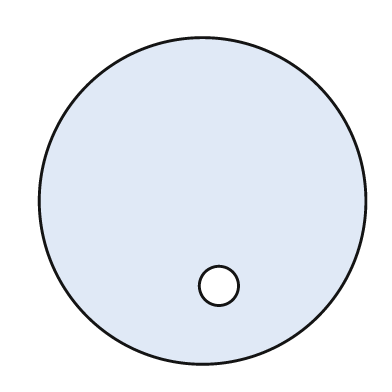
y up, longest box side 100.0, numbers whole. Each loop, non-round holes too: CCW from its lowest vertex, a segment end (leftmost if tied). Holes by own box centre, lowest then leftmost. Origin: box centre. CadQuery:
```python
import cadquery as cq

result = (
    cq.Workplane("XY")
    .moveTo(0.0, 0.0)
    .circle(50.0)
    .moveTo(5.0, -26.0)
    .circle(6.0)
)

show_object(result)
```